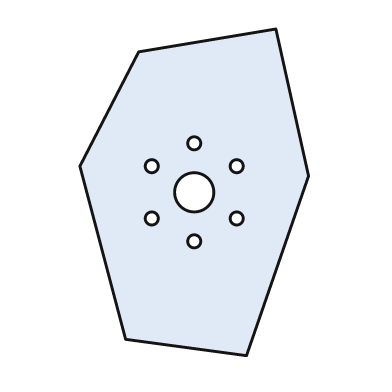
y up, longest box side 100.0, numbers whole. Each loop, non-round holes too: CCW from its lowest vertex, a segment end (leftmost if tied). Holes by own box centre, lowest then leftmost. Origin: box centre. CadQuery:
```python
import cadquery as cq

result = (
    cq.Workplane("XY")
    .moveTo(16.0, -50.0)
    .lineTo(35.0, 5.0)
    .lineTo(25.0, 50.0)
    .lineTo(-17.0, 43.0)
    .lineTo(-35.0, 8.0)
    .lineTo(-21.0, -45.0)
    .close()
    .moveTo(0.0, -15.0)
    .circle(2.0)
    .moveTo(-13.0, -8.0)
    .circle(2.0)
    .moveTo(13.0, -8.0)
    .circle(2.0)
    .moveTo(0.0, 0.0)
    .circle(6.0)
    .moveTo(-13.0, 8.0)
    .circle(2.0)
    .moveTo(13.0, 8.0)
    .circle(2.0)
    .moveTo(0.0, 15.0)
    .circle(2.0)
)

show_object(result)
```